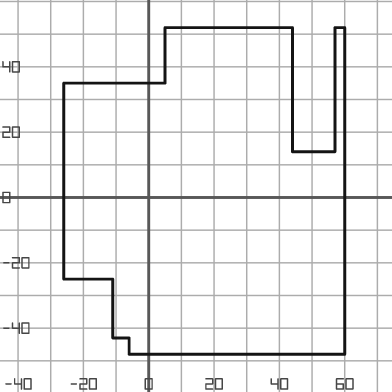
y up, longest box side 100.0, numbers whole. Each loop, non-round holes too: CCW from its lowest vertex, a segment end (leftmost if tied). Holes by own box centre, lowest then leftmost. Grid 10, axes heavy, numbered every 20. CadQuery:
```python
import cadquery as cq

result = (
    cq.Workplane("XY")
    .moveTo(-6.0, -48.0)
    .lineTo(60.0, -48.0)
    .lineTo(60.0, 52.0)
    .lineTo(57.0, 52.0)
    .lineTo(57.0, 14.0)
    .lineTo(44.0, 14.0)
    .lineTo(44.0, 52.0)
    .lineTo(5.0, 52.0)
    .lineTo(5.0, 35.0)
    .lineTo(-26.0, 35.0)
    .lineTo(-26.0, -25.0)
    .lineTo(-11.0, -25.0)
    .lineTo(-11.0, -43.0)
    .lineTo(-6.0, -43.0)
    .close()
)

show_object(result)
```